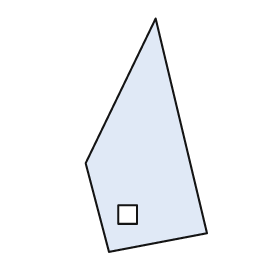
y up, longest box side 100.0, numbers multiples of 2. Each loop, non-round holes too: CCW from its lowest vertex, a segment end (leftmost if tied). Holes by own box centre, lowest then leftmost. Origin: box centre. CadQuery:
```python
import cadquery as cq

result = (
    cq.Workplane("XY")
    .moveTo(-16.0, -50.0)
    .lineTo(26.0, -42.0)
    .lineTo(4.0, 50.0)
    .lineTo(-26.0, -12.0)
    .close()
    .moveTo(-12.0, -38.0)
    .lineTo(-4.0, -38.0)
    .lineTo(-4.0, -30.0)
    .lineTo(-12.0, -30.0)
    .close()
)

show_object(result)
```